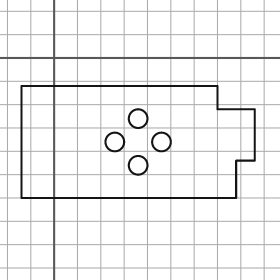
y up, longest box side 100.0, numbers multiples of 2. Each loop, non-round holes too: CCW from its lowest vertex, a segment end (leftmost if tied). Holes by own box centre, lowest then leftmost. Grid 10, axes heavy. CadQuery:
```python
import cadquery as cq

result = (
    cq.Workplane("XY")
    .moveTo(-14.0, -60.0)
    .lineTo(78.0, -60.0)
    .lineTo(78.0, -44.0)
    .lineTo(86.0, -44.0)
    .lineTo(86.0, -22.0)
    .lineTo(70.0, -22.0)
    .lineTo(70.0, -12.0)
    .lineTo(-14.0, -12.0)
    .close()
    .moveTo(36.0, -46.0)
    .circle(4.0)
    .moveTo(26.0, -36.0)
    .circle(4.0)
    .moveTo(46.0, -36.0)
    .circle(4.0)
    .moveTo(36.0, -26.0)
    .circle(4.0)
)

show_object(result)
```